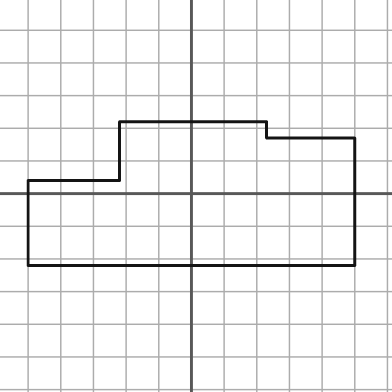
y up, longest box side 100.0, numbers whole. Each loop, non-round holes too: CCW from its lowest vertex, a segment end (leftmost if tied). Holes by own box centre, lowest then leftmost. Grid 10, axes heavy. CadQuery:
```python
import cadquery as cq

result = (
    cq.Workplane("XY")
    .moveTo(-50.0, -22.0)
    .lineTo(50.0, -22.0)
    .lineTo(50.0, 17.0)
    .lineTo(23.0, 17.0)
    .lineTo(23.0, 22.0)
    .lineTo(-22.0, 22.0)
    .lineTo(-22.0, 4.0)
    .lineTo(-50.0, 4.0)
    .close()
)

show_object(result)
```